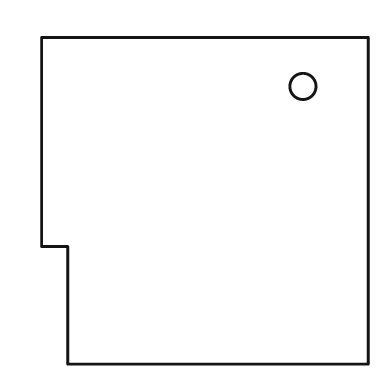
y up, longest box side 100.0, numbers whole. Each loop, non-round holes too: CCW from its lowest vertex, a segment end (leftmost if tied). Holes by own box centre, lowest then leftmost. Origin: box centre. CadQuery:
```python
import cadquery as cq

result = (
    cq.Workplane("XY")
    .moveTo(-42.0, -50.0)
    .lineTo(50.0, -50.0)
    .lineTo(50.0, 50.0)
    .lineTo(-50.0, 50.0)
    .lineTo(-50.0, -14.0)
    .lineTo(-42.0, -14.0)
    .close()
    .moveTo(30.0, 35.0)
    .circle(4.0)
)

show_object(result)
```